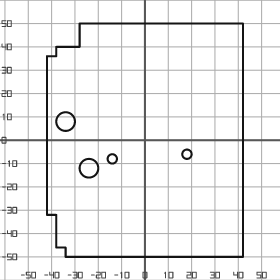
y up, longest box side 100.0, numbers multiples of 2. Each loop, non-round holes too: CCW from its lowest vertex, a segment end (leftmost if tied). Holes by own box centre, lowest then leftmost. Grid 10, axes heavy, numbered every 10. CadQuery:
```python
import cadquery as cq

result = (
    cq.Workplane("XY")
    .moveTo(-34.0, -50.0)
    .lineTo(42.0, -50.0)
    .lineTo(42.0, 50.0)
    .lineTo(-28.0, 50.0)
    .lineTo(-28.0, 40.0)
    .lineTo(-38.0, 40.0)
    .lineTo(-38.0, 36.0)
    .lineTo(-42.0, 36.0)
    .lineTo(-42.0, -32.0)
    .lineTo(-38.0, -32.0)
    .lineTo(-38.0, -46.0)
    .lineTo(-34.0, -46.0)
    .close()
    .moveTo(-24.0, -12.0)
    .circle(4.0)
    .moveTo(-14.0, -8.0)
    .circle(2.0)
    .moveTo(18.0, -6.0)
    .circle(2.0)
    .moveTo(-34.0, 8.0)
    .circle(4.0)
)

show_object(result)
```